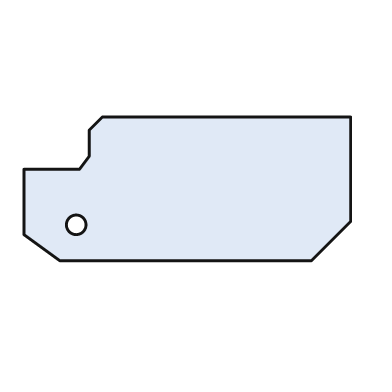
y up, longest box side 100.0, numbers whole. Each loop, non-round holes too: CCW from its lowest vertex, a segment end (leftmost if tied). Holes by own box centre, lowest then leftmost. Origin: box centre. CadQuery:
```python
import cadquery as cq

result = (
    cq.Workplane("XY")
    .moveTo(-39.0, -22.0)
    .lineTo(38.0, -22.0)
    .lineTo(50.0, -10.0)
    .lineTo(50.0, 22.0)
    .lineTo(-26.0, 22.0)
    .lineTo(-30.0, 18.0)
    .lineTo(-30.0, 10.0)
    .lineTo(-33.0, 6.0)
    .lineTo(-50.0, 6.0)
    .lineTo(-50.0, -14.0)
    .close()
    .moveTo(-34.0, -11.0)
    .circle(3.0)
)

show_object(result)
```